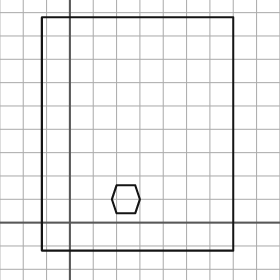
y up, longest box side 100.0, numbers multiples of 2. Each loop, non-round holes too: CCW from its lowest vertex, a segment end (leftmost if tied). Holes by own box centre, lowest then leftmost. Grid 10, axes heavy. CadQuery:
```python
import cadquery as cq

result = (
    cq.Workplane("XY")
    .moveTo(-12.0, -12.0)
    .lineTo(70.0, -12.0)
    .lineTo(70.0, 88.0)
    .lineTo(-12.0, 88.0)
    .close()
    .moveTo(20.0, 4.0)
    .lineTo(28.0, 4.0)
    .lineTo(30.0, 10.0)
    .lineTo(28.0, 16.0)
    .lineTo(20.0, 16.0)
    .lineTo(18.0, 10.0)
    .close()
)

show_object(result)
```